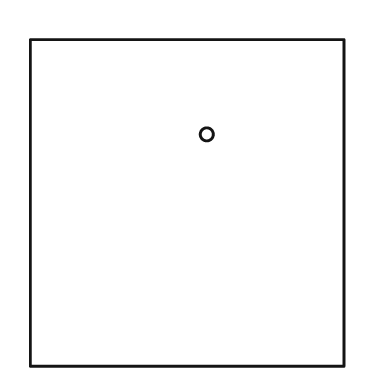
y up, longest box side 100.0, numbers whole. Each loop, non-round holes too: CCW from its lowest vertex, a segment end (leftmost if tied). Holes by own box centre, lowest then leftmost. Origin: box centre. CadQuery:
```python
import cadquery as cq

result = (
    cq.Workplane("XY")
    .moveTo(-48.0, -50.0)
    .lineTo(48.0, -50.0)
    .lineTo(48.0, 50.0)
    .lineTo(-48.0, 50.0)
    .close()
    .moveTo(6.0, 21.0)
    .circle(2.0)
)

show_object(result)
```